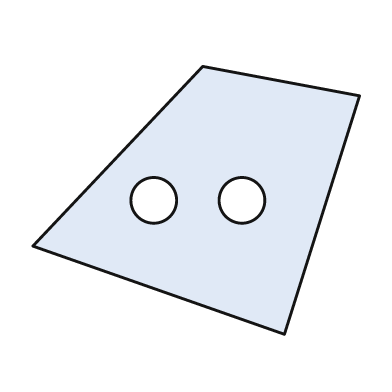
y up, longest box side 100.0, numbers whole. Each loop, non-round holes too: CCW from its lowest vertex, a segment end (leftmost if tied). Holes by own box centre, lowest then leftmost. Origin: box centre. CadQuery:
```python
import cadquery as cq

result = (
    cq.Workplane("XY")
    .moveTo(27.0, -41.0)
    .lineTo(50.0, 32.0)
    .lineTo(2.0, 41.0)
    .lineTo(-50.0, -14.0)
    .close()
    .moveTo(-13.0, 0.0)
    .circle(7.0)
    .moveTo(14.0, 0.0)
    .circle(7.0)
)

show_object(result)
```